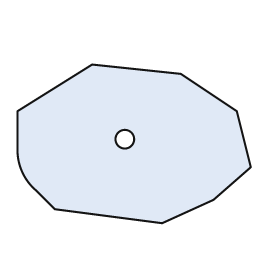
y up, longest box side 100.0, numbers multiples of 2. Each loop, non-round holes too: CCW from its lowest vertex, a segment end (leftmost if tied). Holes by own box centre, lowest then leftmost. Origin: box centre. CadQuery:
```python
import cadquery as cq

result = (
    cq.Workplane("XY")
    .moveTo(12.0, -34.0)
    .lineTo(34.0, -24.0)
    .lineTo(50.0, -10.0)
    .lineTo(44.0, 14.0)
    .lineTo(20.0, 30.0)
    .lineTo(-18.0, 34.0)
    .lineTo(-50.0, 14.0)
    .lineTo(-50.0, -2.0)
    .threePointArc((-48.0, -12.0), (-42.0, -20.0))
    .lineTo(-34.0, -28.0)
    .close()
    .moveTo(-4.0, 2.0)
    .circle(4.0)
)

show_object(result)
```